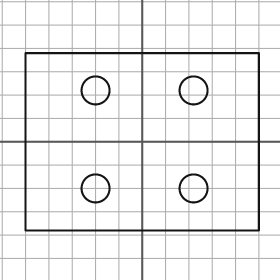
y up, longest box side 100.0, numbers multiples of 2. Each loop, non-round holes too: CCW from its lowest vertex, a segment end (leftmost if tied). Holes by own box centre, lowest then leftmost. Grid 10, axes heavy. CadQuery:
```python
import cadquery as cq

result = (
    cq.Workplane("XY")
    .moveTo(-50.0, -38.0)
    .lineTo(50.0, -38.0)
    .lineTo(50.0, 38.0)
    .lineTo(-50.0, 38.0)
    .close()
    .moveTo(-20.0, -20.0)
    .circle(6.0)
    .moveTo(22.0, -20.0)
    .circle(6.0)
    .moveTo(-20.0, 22.0)
    .circle(6.0)
    .moveTo(22.0, 22.0)
    .circle(6.0)
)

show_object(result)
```